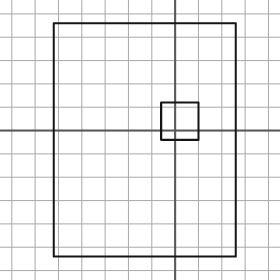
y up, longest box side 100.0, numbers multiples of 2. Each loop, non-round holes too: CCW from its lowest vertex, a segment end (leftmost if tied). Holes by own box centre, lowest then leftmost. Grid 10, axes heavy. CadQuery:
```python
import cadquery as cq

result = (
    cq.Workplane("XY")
    .moveTo(-52.0, -54.0)
    .lineTo(26.0, -54.0)
    .lineTo(26.0, 46.0)
    .lineTo(-52.0, 46.0)
    .close()
    .moveTo(-6.0, -4.0)
    .lineTo(10.0, -4.0)
    .lineTo(10.0, 12.0)
    .lineTo(-6.0, 12.0)
    .close()
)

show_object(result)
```